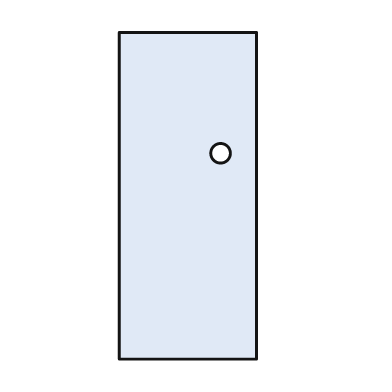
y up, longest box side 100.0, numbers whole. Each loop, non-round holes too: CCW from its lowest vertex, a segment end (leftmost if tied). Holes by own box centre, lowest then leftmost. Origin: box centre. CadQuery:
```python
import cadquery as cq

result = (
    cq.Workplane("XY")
    .moveTo(-21.0, -50.0)
    .lineTo(21.0, -50.0)
    .lineTo(21.0, 50.0)
    .lineTo(-21.0, 50.0)
    .close()
    .moveTo(10.0, 13.0)
    .circle(3.0)
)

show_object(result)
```